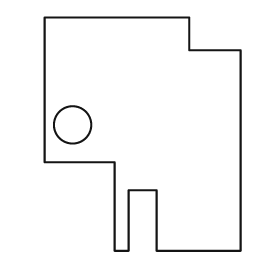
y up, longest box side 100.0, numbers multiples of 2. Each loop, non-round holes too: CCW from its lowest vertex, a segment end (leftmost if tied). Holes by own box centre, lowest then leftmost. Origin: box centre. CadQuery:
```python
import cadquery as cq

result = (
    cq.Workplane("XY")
    .moveTo(-12.0, -50.0)
    .lineTo(-6.0, -50.0)
    .lineTo(-6.0, -24.0)
    .lineTo(6.0, -24.0)
    .lineTo(6.0, -50.0)
    .lineTo(42.0, -50.0)
    .lineTo(42.0, 36.0)
    .lineTo(20.0, 36.0)
    .lineTo(20.0, 50.0)
    .lineTo(-42.0, 50.0)
    .lineTo(-42.0, -12.0)
    .lineTo(-12.0, -12.0)
    .close()
    .moveTo(-30.0, 4.0)
    .circle(8.0)
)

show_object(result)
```